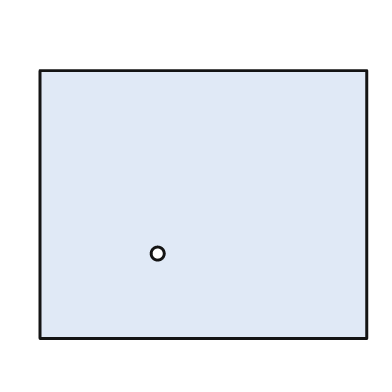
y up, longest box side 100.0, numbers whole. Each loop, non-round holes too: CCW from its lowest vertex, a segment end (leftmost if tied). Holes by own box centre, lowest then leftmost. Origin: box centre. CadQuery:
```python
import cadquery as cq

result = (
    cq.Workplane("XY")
    .moveTo(-50.0, -41.0)
    .lineTo(50.0, -41.0)
    .lineTo(50.0, 41.0)
    .lineTo(-50.0, 41.0)
    .close()
    .moveTo(-14.0, -15.0)
    .circle(2.0)
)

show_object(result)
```